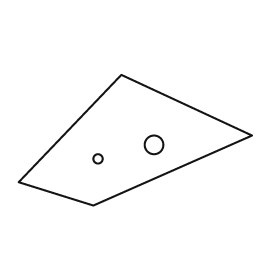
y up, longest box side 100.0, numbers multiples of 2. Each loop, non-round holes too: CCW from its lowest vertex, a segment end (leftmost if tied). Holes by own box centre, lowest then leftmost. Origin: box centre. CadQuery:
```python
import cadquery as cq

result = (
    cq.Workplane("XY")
    .moveTo(-18.0, -28.0)
    .lineTo(50.0, 2.0)
    .lineTo(-6.0, 28.0)
    .lineTo(-50.0, -18.0)
    .close()
    .moveTo(-16.0, -8.0)
    .circle(2.0)
    .moveTo(8.0, -2.0)
    .circle(4.0)
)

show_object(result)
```